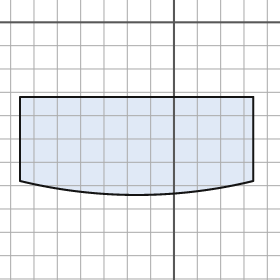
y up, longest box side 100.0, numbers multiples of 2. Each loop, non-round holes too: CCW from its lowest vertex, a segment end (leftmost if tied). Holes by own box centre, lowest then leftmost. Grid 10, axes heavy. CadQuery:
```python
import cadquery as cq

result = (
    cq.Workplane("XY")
    .moveTo(-66.0, -68.0)
    .threePointArc((-16.0, -74.0), (34.0, -68.0))
    .lineTo(34.0, -32.0)
    .lineTo(-66.0, -32.0)
    .close()
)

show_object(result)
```